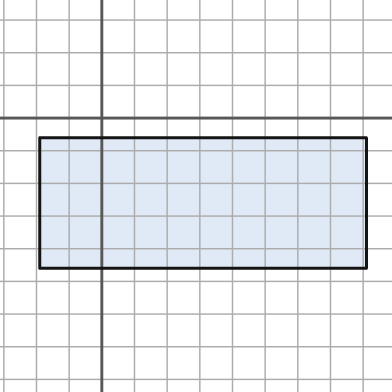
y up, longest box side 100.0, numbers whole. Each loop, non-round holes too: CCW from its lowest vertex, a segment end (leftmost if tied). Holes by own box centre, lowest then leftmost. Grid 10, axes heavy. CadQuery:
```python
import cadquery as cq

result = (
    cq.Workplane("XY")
    .moveTo(-19.0, -46.0)
    .lineTo(81.0, -46.0)
    .lineTo(81.0, -6.0)
    .lineTo(-19.0, -6.0)
    .close()
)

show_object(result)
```